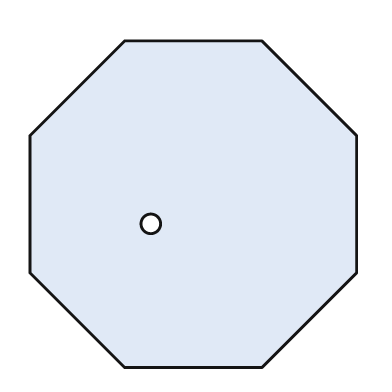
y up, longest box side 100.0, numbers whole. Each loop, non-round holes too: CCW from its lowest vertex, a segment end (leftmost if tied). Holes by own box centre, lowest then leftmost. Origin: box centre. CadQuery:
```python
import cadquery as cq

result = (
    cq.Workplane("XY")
    .moveTo(-21.0, -50.0)
    .lineTo(21.0, -50.0)
    .lineTo(50.0, -21.0)
    .lineTo(50.0, 21.0)
    .lineTo(21.0, 50.0)
    .lineTo(-21.0, 50.0)
    .lineTo(-50.0, 21.0)
    .lineTo(-50.0, -21.0)
    .close()
    .moveTo(-13.0, -6.0)
    .circle(3.0)
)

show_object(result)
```